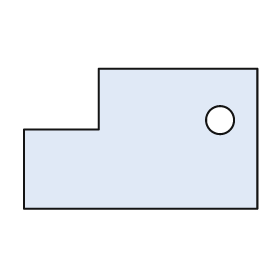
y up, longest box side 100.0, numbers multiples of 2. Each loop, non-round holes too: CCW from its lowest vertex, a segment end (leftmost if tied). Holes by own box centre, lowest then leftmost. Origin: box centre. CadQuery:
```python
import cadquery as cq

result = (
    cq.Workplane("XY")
    .moveTo(-50.0, -30.0)
    .lineTo(50.0, -30.0)
    .lineTo(50.0, 30.0)
    .lineTo(-18.0, 30.0)
    .lineTo(-18.0, 4.0)
    .lineTo(-50.0, 4.0)
    .close()
    .moveTo(34.0, 8.0)
    .circle(6.0)
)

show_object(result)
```